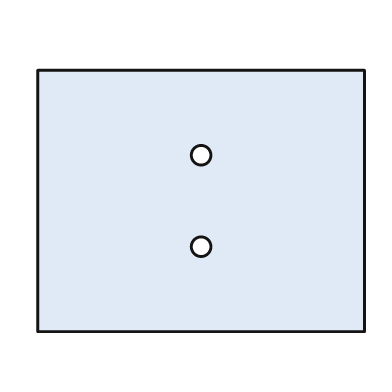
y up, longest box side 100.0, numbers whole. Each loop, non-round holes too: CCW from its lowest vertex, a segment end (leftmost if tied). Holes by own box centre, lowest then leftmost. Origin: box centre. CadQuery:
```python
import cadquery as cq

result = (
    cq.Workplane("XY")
    .moveTo(-50.0, -40.0)
    .lineTo(50.0, -40.0)
    .lineTo(50.0, 40.0)
    .lineTo(-50.0, 40.0)
    .close()
    .moveTo(0.0, -14.0)
    .circle(3.0)
    .moveTo(0.0, 14.0)
    .circle(3.0)
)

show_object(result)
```